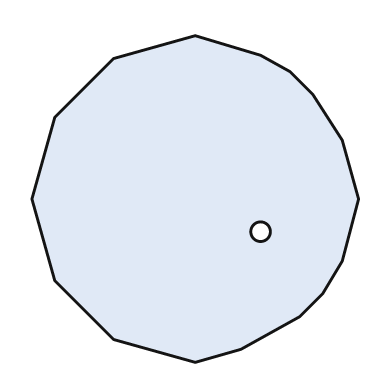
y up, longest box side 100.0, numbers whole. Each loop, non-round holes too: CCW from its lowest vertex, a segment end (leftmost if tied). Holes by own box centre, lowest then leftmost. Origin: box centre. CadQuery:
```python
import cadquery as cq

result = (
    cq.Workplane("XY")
    .moveTo(0.0, -50.0)
    .lineTo(14.0, -46.0)
    .lineTo(32.0, -36.0)
    .lineTo(39.0, -29.0)
    .lineTo(45.0, -19.0)
    .lineTo(50.0, 0.0)
    .lineTo(45.0, 18.0)
    .lineTo(36.0, 32.0)
    .lineTo(29.0, 39.0)
    .lineTo(20.0, 44.0)
    .lineTo(0.0, 50.0)
    .lineTo(-25.0, 43.0)
    .lineTo(-43.0, 25.0)
    .lineTo(-50.0, 0.0)
    .lineTo(-43.0, -25.0)
    .lineTo(-25.0, -43.0)
    .close()
    .moveTo(20.0, -10.0)
    .circle(3.0)
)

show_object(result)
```